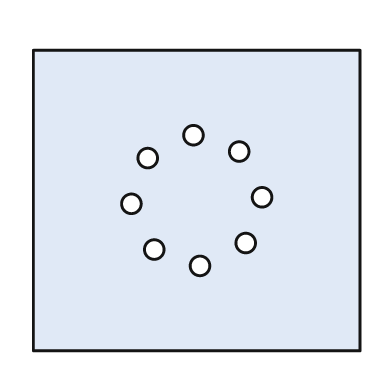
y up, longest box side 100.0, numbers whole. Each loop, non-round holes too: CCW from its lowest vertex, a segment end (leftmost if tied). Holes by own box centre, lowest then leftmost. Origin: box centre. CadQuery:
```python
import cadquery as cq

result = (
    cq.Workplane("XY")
    .moveTo(-50.0, -46.0)
    .lineTo(50.0, -46.0)
    .lineTo(50.0, 46.0)
    .lineTo(-50.0, 46.0)
    .close()
    .moveTo(1.0, -20.0)
    .circle(3.0)
    .moveTo(-13.0, -15.0)
    .circle(3.0)
    .moveTo(15.0, -13.0)
    .circle(3.0)
    .moveTo(-20.0, -1.0)
    .circle(3.0)
    .moveTo(20.0, 1.0)
    .circle(3.0)
    .moveTo(-15.0, 13.0)
    .circle(3.0)
    .moveTo(13.0, 15.0)
    .circle(3.0)
    .moveTo(-1.0, 20.0)
    .circle(3.0)
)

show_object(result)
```